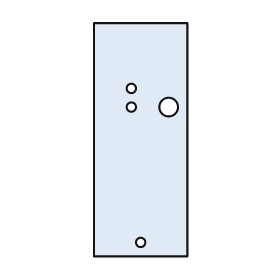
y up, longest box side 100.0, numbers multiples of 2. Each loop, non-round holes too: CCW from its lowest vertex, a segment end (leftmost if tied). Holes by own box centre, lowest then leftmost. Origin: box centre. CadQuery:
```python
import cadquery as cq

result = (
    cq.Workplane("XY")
    .moveTo(-20.0, -50.0)
    .lineTo(20.0, -50.0)
    .lineTo(20.0, 50.0)
    .lineTo(-20.0, 50.0)
    .close()
    .moveTo(0.0, -44.0)
    .circle(2.0)
    .moveTo(-4.0, 14.0)
    .circle(2.0)
    .moveTo(12.0, 14.0)
    .circle(4.0)
    .moveTo(-4.0, 22.0)
    .circle(2.0)
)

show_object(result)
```